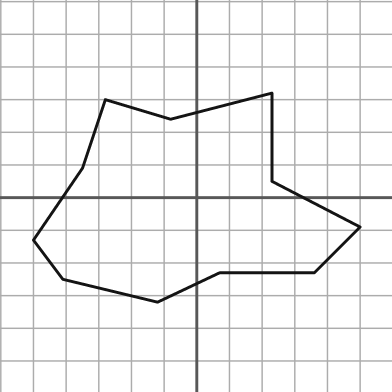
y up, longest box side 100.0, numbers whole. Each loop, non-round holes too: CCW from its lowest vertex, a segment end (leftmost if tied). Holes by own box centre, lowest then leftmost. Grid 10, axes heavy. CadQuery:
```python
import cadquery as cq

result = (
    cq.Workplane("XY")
    .moveTo(-12.0, -32.0)
    .lineTo(7.0, -23.0)
    .lineTo(36.0, -23.0)
    .lineTo(50.0, -9.0)
    .lineTo(23.0, 5.0)
    .lineTo(23.0, 32.0)
    .lineTo(-8.0, 24.0)
    .lineTo(-28.0, 30.0)
    .lineTo(-35.0, 9.0)
    .lineTo(-50.0, -13.0)
    .lineTo(-41.0, -25.0)
    .close()
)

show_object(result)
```